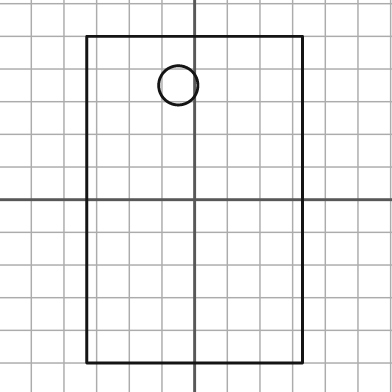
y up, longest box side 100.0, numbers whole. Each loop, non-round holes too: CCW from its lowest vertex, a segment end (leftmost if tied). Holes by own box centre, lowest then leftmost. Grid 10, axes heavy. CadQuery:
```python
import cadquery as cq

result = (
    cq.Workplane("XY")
    .moveTo(-33.0, -50.0)
    .lineTo(33.0, -50.0)
    .lineTo(33.0, 50.0)
    .lineTo(-33.0, 50.0)
    .close()
    .moveTo(-5.0, 35.0)
    .circle(6.0)
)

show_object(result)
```